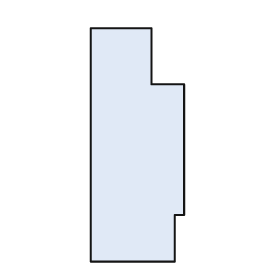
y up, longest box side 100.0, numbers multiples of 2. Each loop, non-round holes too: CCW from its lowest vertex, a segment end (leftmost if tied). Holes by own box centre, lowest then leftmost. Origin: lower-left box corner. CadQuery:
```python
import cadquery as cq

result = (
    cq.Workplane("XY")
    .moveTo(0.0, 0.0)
    .lineTo(36.0, 0.0)
    .lineTo(36.0, 20.0)
    .lineTo(40.0, 20.0)
    .lineTo(40.0, 76.0)
    .lineTo(26.0, 76.0)
    .lineTo(26.0, 100.0)
    .lineTo(0.0, 100.0)
    .close()
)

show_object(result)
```